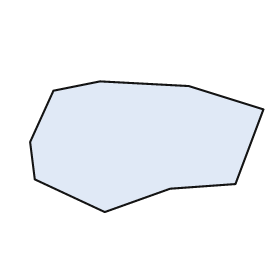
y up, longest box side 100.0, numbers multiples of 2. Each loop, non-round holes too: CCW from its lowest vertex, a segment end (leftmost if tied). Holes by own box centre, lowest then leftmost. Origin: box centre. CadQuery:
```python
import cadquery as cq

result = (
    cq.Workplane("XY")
    .moveTo(-18.0, -28.0)
    .lineTo(10.0, -18.0)
    .lineTo(38.0, -16.0)
    .lineTo(50.0, 16.0)
    .lineTo(18.0, 26.0)
    .lineTo(-20.0, 28.0)
    .lineTo(-40.0, 24.0)
    .lineTo(-50.0, 2.0)
    .lineTo(-48.0, -14.0)
    .close()
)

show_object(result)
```